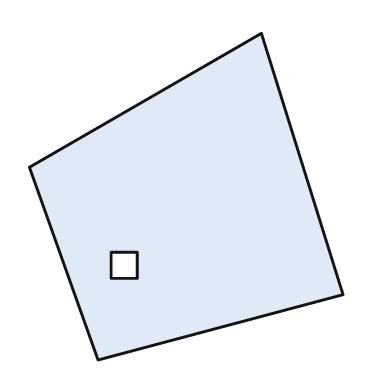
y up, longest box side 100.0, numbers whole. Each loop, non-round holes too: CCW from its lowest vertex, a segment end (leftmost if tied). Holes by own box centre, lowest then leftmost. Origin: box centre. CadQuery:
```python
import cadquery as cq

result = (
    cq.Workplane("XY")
    .moveTo(-27.0, -50.0)
    .lineTo(48.0, -30.0)
    .lineTo(23.0, 50.0)
    .lineTo(-48.0, 9.0)
    .close()
    .moveTo(-23.0, -25.0)
    .lineTo(-15.0, -25.0)
    .lineTo(-15.0, -17.0)
    .lineTo(-23.0, -17.0)
    .close()
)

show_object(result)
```